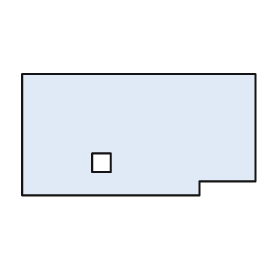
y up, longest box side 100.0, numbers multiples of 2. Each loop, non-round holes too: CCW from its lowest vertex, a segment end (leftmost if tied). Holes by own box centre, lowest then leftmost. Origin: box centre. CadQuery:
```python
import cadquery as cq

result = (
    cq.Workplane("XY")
    .moveTo(-50.0, -26.0)
    .lineTo(26.0, -26.0)
    .lineTo(26.0, -20.0)
    .lineTo(50.0, -20.0)
    .lineTo(50.0, 26.0)
    .lineTo(-50.0, 26.0)
    .close()
    .moveTo(-20.0, -16.0)
    .lineTo(-12.0, -16.0)
    .lineTo(-12.0, -8.0)
    .lineTo(-20.0, -8.0)
    .close()
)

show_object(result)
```